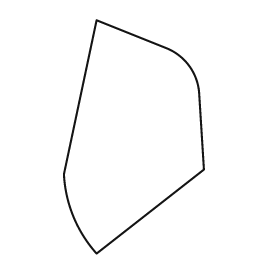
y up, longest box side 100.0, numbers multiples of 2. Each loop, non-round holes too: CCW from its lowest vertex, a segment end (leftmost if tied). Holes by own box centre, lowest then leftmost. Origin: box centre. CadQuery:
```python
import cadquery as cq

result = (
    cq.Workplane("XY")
    .moveTo(-16.0, -50.0)
    .lineTo(30.0, -14.0)
    .lineTo(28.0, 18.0)
    .threePointArc((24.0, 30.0), (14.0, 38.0))
    .lineTo(-16.0, 50.0)
    .lineTo(-30.0, -16.0)
    .threePointArc((-26.0, -34.0), (-16.0, -50.0))
    .close()
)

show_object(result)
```